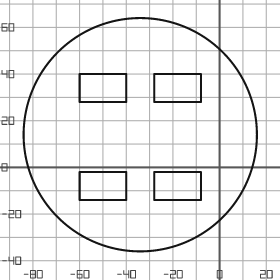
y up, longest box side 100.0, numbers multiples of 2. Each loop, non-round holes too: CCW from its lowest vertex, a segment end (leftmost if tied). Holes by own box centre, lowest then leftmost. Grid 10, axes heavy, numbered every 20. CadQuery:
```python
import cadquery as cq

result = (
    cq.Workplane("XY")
    .moveTo(-34.0, 14.0)
    .circle(50.0)
    .moveTo(-60.0, -14.0)
    .lineTo(-40.0, -14.0)
    .lineTo(-40.0, -2.0)
    .lineTo(-60.0, -2.0)
    .close()
    .moveTo(-28.0, -14.0)
    .lineTo(-8.0, -14.0)
    .lineTo(-8.0, -2.0)
    .lineTo(-28.0, -2.0)
    .close()
    .moveTo(-60.0, 28.0)
    .lineTo(-40.0, 28.0)
    .lineTo(-40.0, 40.0)
    .lineTo(-60.0, 40.0)
    .close()
    .moveTo(-28.0, 28.0)
    .lineTo(-8.0, 28.0)
    .lineTo(-8.0, 40.0)
    .lineTo(-28.0, 40.0)
    .close()
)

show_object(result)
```